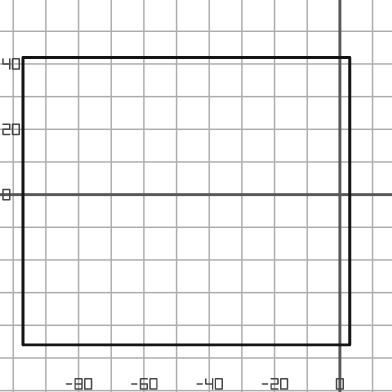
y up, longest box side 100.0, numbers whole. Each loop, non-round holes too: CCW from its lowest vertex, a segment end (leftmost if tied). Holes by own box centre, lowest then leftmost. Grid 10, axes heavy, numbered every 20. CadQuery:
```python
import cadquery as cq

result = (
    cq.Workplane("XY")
    .moveTo(-97.0, -46.0)
    .lineTo(3.0, -46.0)
    .lineTo(3.0, 42.0)
    .lineTo(-97.0, 42.0)
    .close()
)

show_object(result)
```